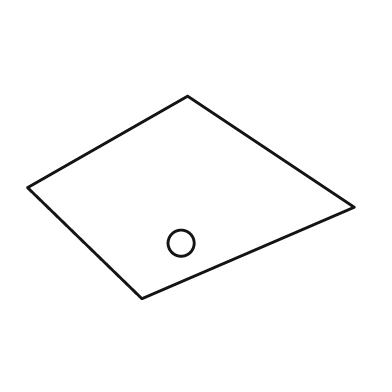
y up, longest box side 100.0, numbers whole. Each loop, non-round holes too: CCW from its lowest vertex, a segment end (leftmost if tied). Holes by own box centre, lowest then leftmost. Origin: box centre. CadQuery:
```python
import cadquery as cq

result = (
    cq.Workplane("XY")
    .moveTo(-15.0, -31.0)
    .lineTo(50.0, -3.0)
    .lineTo(-1.0, 31.0)
    .lineTo(-50.0, 3.0)
    .close()
    .moveTo(-3.0, -14.0)
    .circle(4.0)
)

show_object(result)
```